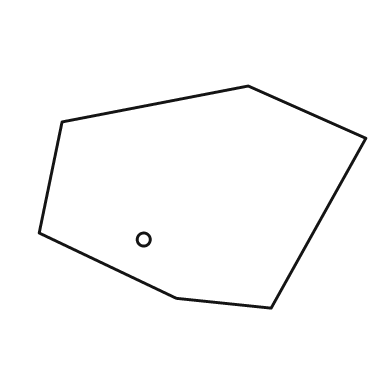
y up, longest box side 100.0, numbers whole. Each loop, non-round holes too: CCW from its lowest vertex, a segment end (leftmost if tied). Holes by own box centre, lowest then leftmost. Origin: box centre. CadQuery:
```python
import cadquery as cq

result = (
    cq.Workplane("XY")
    .moveTo(21.0, -34.0)
    .lineTo(50.0, 18.0)
    .lineTo(14.0, 34.0)
    .lineTo(-43.0, 23.0)
    .lineTo(-50.0, -11.0)
    .lineTo(-8.0, -31.0)
    .close()
    .moveTo(-18.0, -13.0)
    .circle(2.0)
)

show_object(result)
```